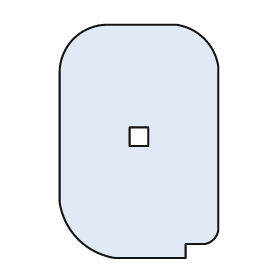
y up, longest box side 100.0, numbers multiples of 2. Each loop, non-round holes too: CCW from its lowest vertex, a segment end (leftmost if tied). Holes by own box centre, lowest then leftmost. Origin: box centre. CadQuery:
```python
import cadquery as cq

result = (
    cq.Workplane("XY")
    .moveTo(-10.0, -50.0)
    .lineTo(20.0, -50.0)
    .lineTo(20.0, -44.0)
    .lineTo(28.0, -44.0)
    .threePointArc((32.0, -42.0), (34.0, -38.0))
    .lineTo(34.0, 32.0)
    .threePointArc((28.0, 44.0), (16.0, 50.0))
    .lineTo(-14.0, 50.0)
    .threePointArc((-28.0, 44.0), (-34.0, 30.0))
    .lineTo(-34.0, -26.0)
    .threePointArc((-26.0, -42.0), (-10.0, -50.0))
    .close()
    .moveTo(-4.0, -2.0)
    .lineTo(4.0, -2.0)
    .lineTo(4.0, 6.0)
    .lineTo(-4.0, 6.0)
    .close()
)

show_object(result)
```